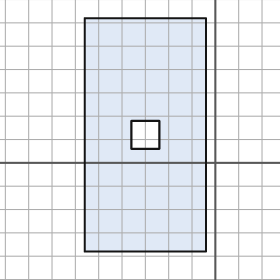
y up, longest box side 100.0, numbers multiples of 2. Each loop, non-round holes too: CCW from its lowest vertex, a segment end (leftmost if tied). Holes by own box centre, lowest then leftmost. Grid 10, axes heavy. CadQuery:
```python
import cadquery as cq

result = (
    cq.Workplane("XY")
    .moveTo(-56.0, -38.0)
    .lineTo(-4.0, -38.0)
    .lineTo(-4.0, 62.0)
    .lineTo(-56.0, 62.0)
    .close()
    .moveTo(-36.0, 6.0)
    .lineTo(-24.0, 6.0)
    .lineTo(-24.0, 18.0)
    .lineTo(-36.0, 18.0)
    .close()
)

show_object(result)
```